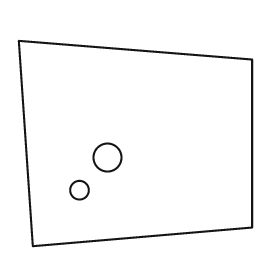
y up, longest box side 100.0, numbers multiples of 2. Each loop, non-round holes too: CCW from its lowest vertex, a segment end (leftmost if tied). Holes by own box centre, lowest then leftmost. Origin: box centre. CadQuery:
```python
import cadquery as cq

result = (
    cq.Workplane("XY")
    .moveTo(-44.0, -44.0)
    .lineTo(50.0, -36.0)
    .lineTo(50.0, 36.0)
    .lineTo(-50.0, 44.0)
    .close()
    .moveTo(-24.0, -20.0)
    .circle(4.0)
    .moveTo(-12.0, -6.0)
    .circle(6.0)
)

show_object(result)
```